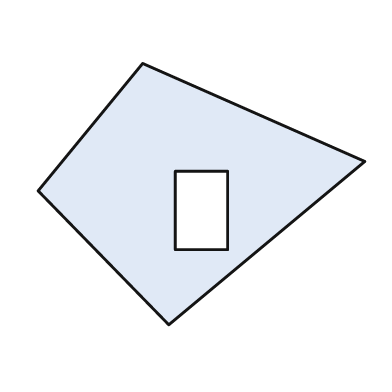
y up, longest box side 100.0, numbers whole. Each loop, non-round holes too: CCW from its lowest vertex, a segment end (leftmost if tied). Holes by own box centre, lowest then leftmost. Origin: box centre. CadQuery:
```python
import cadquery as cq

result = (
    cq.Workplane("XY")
    .moveTo(-10.0, -40.0)
    .lineTo(50.0, 10.0)
    .lineTo(-18.0, 40.0)
    .lineTo(-50.0, 1.0)
    .close()
    .moveTo(-8.0, -17.0)
    .lineTo(8.0, -17.0)
    .lineTo(8.0, 7.0)
    .lineTo(-8.0, 7.0)
    .close()
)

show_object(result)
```